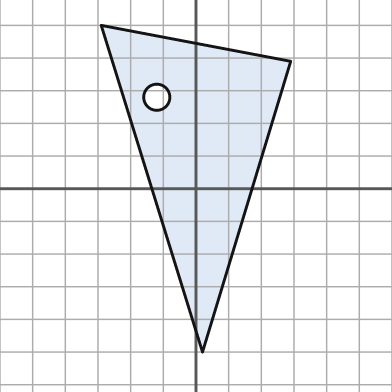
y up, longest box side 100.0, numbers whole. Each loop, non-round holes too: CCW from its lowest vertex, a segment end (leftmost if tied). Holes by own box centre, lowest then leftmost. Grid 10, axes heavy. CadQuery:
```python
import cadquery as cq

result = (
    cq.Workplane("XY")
    .moveTo(2.0, -50.0)
    .lineTo(29.0, 39.0)
    .lineTo(-29.0, 50.0)
    .close()
    .moveTo(-12.0, 28.0)
    .circle(4.0)
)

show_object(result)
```